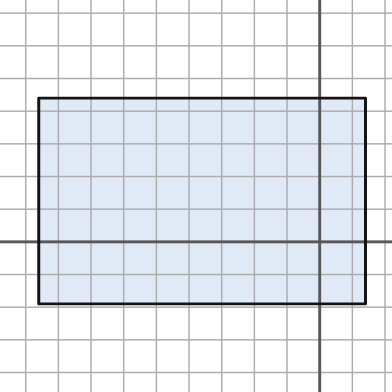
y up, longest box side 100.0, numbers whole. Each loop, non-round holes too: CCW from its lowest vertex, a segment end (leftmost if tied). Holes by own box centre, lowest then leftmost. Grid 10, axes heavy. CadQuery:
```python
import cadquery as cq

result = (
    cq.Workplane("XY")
    .moveTo(-86.0, -19.0)
    .lineTo(14.0, -19.0)
    .lineTo(14.0, 44.0)
    .lineTo(-86.0, 44.0)
    .close()
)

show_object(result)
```